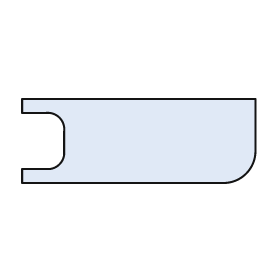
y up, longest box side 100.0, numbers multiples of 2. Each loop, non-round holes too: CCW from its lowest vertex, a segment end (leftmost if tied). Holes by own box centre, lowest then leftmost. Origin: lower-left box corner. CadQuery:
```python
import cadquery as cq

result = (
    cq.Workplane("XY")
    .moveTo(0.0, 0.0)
    .lineTo(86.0, 0.0)
    .threePointArc((96.0, 4.0), (100.0, 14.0))
    .lineTo(100.0, 36.0)
    .lineTo(0.0, 36.0)
    .lineTo(0.0, 30.0)
    .lineTo(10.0, 30.0)
    .threePointArc((16.0, 28.0), (18.0, 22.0))
    .lineTo(18.0, 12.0)
    .threePointArc((16.0, 8.0), (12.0, 6.0))
    .lineTo(0.0, 6.0)
    .close()
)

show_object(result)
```